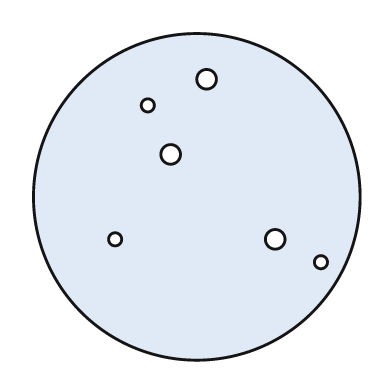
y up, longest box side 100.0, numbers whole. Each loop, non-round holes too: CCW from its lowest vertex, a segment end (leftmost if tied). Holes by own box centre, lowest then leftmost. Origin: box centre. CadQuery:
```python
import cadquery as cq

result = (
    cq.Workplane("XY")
    .moveTo(0.0, 0.0)
    .circle(50.0)
    .moveTo(38.0, -20.0)
    .circle(2.0)
    .moveTo(-25.0, -13.0)
    .circle(2.0)
    .moveTo(24.0, -13.0)
    .circle(3.0)
    .moveTo(-8.0, 13.0)
    .circle(3.0)
    .moveTo(-15.0, 28.0)
    .circle(2.0)
    .moveTo(3.0, 36.0)
    .circle(3.0)
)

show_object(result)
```